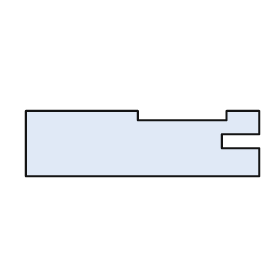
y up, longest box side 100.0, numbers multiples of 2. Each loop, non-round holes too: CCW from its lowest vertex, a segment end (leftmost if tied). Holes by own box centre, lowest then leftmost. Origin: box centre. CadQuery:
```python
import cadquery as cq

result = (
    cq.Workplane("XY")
    .moveTo(-50.0, -14.0)
    .lineTo(50.0, -14.0)
    .lineTo(50.0, -2.0)
    .lineTo(34.0, -2.0)
    .lineTo(34.0, 4.0)
    .lineTo(50.0, 4.0)
    .lineTo(50.0, 14.0)
    .lineTo(36.0, 14.0)
    .lineTo(36.0, 10.0)
    .lineTo(-2.0, 10.0)
    .lineTo(-2.0, 14.0)
    .lineTo(-50.0, 14.0)
    .close()
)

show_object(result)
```